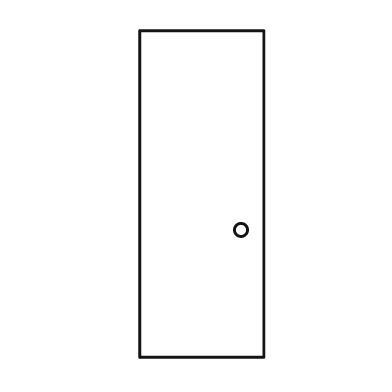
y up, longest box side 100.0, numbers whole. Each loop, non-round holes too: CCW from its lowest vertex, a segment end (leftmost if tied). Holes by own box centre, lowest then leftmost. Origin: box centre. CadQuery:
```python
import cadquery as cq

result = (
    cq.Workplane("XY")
    .moveTo(-19.0, -50.0)
    .lineTo(19.0, -50.0)
    .lineTo(19.0, 50.0)
    .lineTo(-19.0, 50.0)
    .close()
    .moveTo(12.0, -11.0)
    .circle(2.0)
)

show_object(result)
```